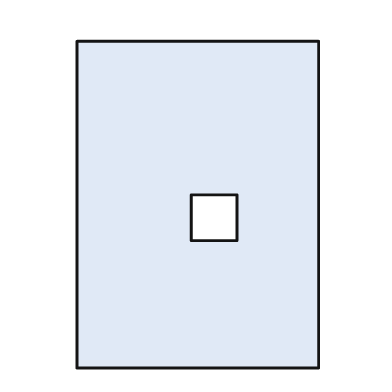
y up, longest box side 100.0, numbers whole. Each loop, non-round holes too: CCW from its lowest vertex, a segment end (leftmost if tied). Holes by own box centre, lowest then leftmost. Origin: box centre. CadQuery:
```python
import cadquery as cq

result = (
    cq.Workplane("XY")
    .moveTo(-37.0, -50.0)
    .lineTo(37.0, -50.0)
    .lineTo(37.0, 50.0)
    .lineTo(-37.0, 50.0)
    .close()
    .moveTo(-2.0, -11.0)
    .lineTo(12.0, -11.0)
    .lineTo(12.0, 3.0)
    .lineTo(-2.0, 3.0)
    .close()
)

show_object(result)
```